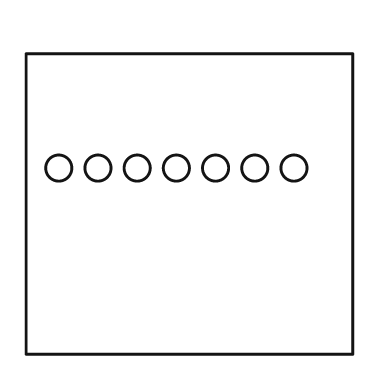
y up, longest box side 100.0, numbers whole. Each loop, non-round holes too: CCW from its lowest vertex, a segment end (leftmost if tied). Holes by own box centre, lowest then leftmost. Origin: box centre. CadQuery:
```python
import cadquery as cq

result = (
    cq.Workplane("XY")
    .moveTo(-50.0, -46.0)
    .lineTo(50.0, -46.0)
    .lineTo(50.0, 46.0)
    .lineTo(-50.0, 46.0)
    .close()
    .moveTo(-40.0, 11.0)
    .circle(4.0)
    .moveTo(-28.0, 11.0)
    .circle(4.0)
    .moveTo(-16.0, 11.0)
    .circle(4.0)
    .moveTo(-4.0, 11.0)
    .circle(4.0)
    .moveTo(8.0, 11.0)
    .circle(4.0)
    .moveTo(20.0, 11.0)
    .circle(4.0)
    .moveTo(32.0, 11.0)
    .circle(4.0)
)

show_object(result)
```